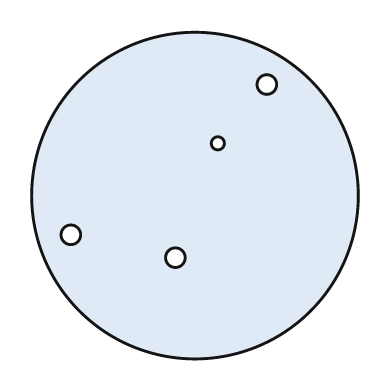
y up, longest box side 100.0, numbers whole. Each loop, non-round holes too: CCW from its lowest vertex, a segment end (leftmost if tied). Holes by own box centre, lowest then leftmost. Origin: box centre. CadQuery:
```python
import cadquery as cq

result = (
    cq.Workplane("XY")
    .moveTo(0.0, 0.0)
    .circle(50.0)
    .moveTo(-6.0, -19.0)
    .circle(3.0)
    .moveTo(-38.0, -12.0)
    .circle(3.0)
    .moveTo(7.0, 16.0)
    .circle(2.0)
    .moveTo(22.0, 34.0)
    .circle(3.0)
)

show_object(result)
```